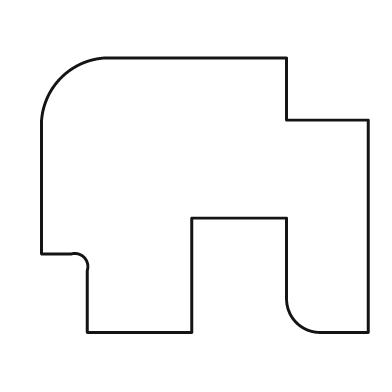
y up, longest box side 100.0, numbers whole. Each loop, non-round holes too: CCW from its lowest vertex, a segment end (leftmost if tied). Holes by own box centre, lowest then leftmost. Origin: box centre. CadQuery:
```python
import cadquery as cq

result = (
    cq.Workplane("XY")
    .moveTo(-36.0, -42.0)
    .lineTo(-4.0, -42.0)
    .lineTo(-4.0, -7.0)
    .lineTo(25.0, -7.0)
    .lineTo(25.0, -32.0)
    .threePointArc((28.0, -39.0), (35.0, -42.0))
    .lineTo(50.0, -42.0)
    .lineTo(50.0, 23.0)
    .lineTo(25.0, 23.0)
    .lineTo(25.0, 42.0)
    .lineTo(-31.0, 42.0)
    .threePointArc((-44.0, 36.0), (-50.0, 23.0))
    .lineTo(-50.0, -18.0)
    .lineTo(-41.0, -18.0)
    .threePointArc((-37.0, -19.0), (-36.0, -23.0))
    .close()
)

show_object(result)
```